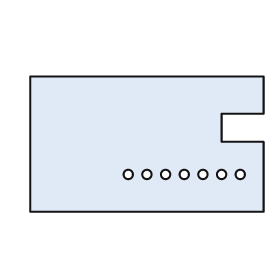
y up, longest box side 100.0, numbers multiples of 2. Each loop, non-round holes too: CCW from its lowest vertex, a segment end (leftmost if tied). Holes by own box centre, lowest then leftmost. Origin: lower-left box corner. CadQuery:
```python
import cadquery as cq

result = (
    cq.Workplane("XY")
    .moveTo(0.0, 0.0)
    .lineTo(100.0, 0.0)
    .lineTo(100.0, 30.0)
    .lineTo(82.0, 30.0)
    .lineTo(82.0, 42.0)
    .lineTo(100.0, 42.0)
    .lineTo(100.0, 58.0)
    .lineTo(0.0, 58.0)
    .close()
    .moveTo(42.0, 16.0)
    .circle(2.0)
    .moveTo(50.0, 16.0)
    .circle(2.0)
    .moveTo(58.0, 16.0)
    .circle(2.0)
    .moveTo(66.0, 16.0)
    .circle(2.0)
    .moveTo(74.0, 16.0)
    .circle(2.0)
    .moveTo(82.0, 16.0)
    .circle(2.0)
    .moveTo(90.0, 16.0)
    .circle(2.0)
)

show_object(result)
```